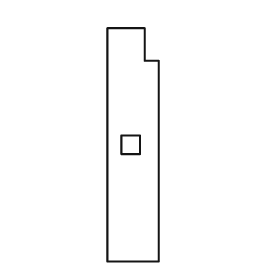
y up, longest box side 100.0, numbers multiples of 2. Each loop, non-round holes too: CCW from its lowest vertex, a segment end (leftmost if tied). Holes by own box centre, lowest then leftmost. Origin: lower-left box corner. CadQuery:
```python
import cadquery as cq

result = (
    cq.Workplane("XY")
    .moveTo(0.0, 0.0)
    .lineTo(22.0, 0.0)
    .lineTo(22.0, 86.0)
    .lineTo(16.0, 86.0)
    .lineTo(16.0, 100.0)
    .lineTo(0.0, 100.0)
    .close()
    .moveTo(6.0, 46.0)
    .lineTo(14.0, 46.0)
    .lineTo(14.0, 54.0)
    .lineTo(6.0, 54.0)
    .close()
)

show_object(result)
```